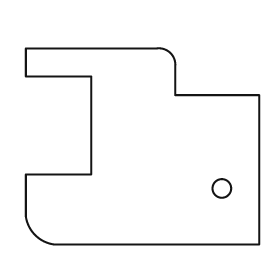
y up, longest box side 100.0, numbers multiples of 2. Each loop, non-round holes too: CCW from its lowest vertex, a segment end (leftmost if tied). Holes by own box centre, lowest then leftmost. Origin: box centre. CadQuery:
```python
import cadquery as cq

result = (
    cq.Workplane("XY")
    .moveTo(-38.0, -42.0)
    .lineTo(50.0, -42.0)
    .lineTo(50.0, 22.0)
    .lineTo(14.0, 22.0)
    .lineTo(14.0, 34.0)
    .threePointArc((12.0, 40.0), (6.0, 42.0))
    .lineTo(-50.0, 42.0)
    .lineTo(-50.0, 30.0)
    .lineTo(-22.0, 30.0)
    .lineTo(-22.0, -12.0)
    .lineTo(-50.0, -12.0)
    .lineTo(-50.0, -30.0)
    .threePointArc((-46.0, -38.0), (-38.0, -42.0))
    .close()
    .moveTo(34.0, -18.0)
    .circle(4.0)
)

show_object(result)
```